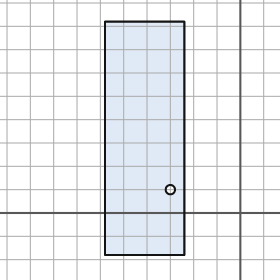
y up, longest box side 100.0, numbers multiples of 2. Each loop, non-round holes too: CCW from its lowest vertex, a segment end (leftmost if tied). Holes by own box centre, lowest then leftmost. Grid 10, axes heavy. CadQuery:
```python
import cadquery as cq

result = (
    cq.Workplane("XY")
    .moveTo(-58.0, -18.0)
    .lineTo(-24.0, -18.0)
    .lineTo(-24.0, 82.0)
    .lineTo(-58.0, 82.0)
    .close()
    .moveTo(-30.0, 10.0)
    .circle(2.0)
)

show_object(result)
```